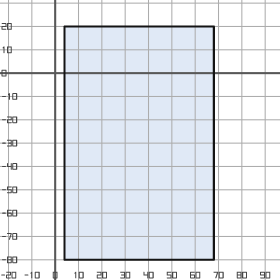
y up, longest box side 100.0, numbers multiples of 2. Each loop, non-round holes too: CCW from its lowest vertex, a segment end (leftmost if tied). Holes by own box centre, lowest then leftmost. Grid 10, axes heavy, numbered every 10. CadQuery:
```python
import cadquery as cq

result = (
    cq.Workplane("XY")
    .moveTo(4.0, -80.0)
    .lineTo(68.0, -80.0)
    .lineTo(68.0, 20.0)
    .lineTo(4.0, 20.0)
    .close()
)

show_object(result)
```